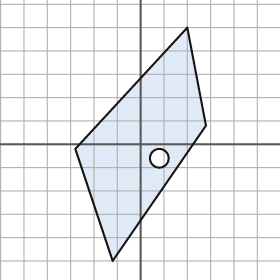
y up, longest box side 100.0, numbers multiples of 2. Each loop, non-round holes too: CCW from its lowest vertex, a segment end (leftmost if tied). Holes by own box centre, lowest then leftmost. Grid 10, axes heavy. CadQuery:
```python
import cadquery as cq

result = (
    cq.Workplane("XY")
    .moveTo(-12.0, -50.0)
    .lineTo(28.0, 8.0)
    .lineTo(20.0, 50.0)
    .lineTo(-28.0, -2.0)
    .close()
    .moveTo(8.0, -6.0)
    .circle(4.0)
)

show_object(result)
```